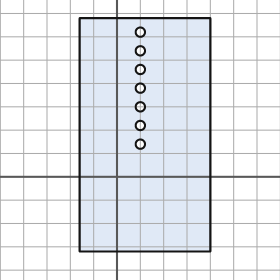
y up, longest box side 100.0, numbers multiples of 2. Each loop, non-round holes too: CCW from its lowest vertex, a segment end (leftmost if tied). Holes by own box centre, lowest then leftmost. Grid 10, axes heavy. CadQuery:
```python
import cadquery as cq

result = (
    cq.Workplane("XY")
    .moveTo(-16.0, -32.0)
    .lineTo(40.0, -32.0)
    .lineTo(40.0, 68.0)
    .lineTo(-16.0, 68.0)
    .close()
    .moveTo(10.0, 14.0)
    .circle(2.0)
    .moveTo(10.0, 22.0)
    .circle(2.0)
    .moveTo(10.0, 30.0)
    .circle(2.0)
    .moveTo(10.0, 38.0)
    .circle(2.0)
    .moveTo(10.0, 46.0)
    .circle(2.0)
    .moveTo(10.0, 54.0)
    .circle(2.0)
    .moveTo(10.0, 62.0)
    .circle(2.0)
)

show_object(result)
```